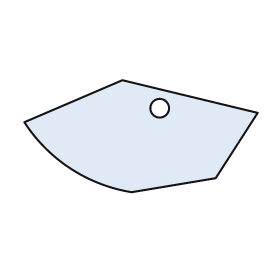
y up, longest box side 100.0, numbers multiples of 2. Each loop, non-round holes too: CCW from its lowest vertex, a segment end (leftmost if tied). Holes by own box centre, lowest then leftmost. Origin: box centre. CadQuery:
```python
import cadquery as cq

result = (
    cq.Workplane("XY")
    .moveTo(-4.0, -24.0)
    .lineTo(32.0, -18.0)
    .lineTo(50.0, 10.0)
    .lineTo(-8.0, 24.0)
    .lineTo(-50.0, 6.0)
    .threePointArc((-30.0, -14.0), (-4.0, -24.0))
    .close()
    .moveTo(8.0, 12.0)
    .circle(4.0)
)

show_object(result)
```